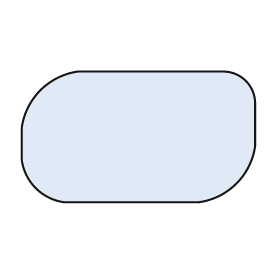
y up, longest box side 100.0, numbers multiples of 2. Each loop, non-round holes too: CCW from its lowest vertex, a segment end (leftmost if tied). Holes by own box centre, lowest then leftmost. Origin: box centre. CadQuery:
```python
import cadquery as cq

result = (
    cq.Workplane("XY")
    .moveTo(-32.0, -28.0)
    .lineTo(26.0, -28.0)
    .threePointArc((42.0, -20.0), (50.0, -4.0))
    .lineTo(50.0, 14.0)
    .threePointArc((46.0, 24.0), (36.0, 28.0))
    .lineTo(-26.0, 28.0)
    .threePointArc((-42.0, 20.0), (-50.0, 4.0))
    .lineTo(-50.0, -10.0)
    .threePointArc((-44.0, -22.0), (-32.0, -28.0))
    .close()
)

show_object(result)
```